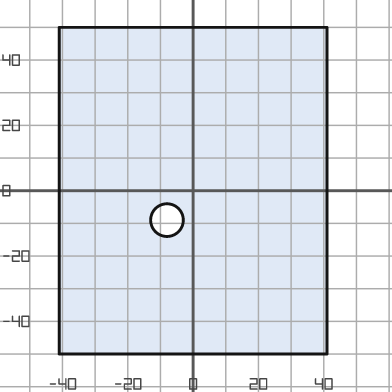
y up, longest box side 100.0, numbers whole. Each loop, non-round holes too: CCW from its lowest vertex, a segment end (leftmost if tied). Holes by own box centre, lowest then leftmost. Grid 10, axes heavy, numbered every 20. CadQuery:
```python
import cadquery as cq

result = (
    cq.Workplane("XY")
    .moveTo(-41.0, -50.0)
    .lineTo(41.0, -50.0)
    .lineTo(41.0, 50.0)
    .lineTo(-41.0, 50.0)
    .close()
    .moveTo(-8.0, -9.0)
    .circle(5.0)
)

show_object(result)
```